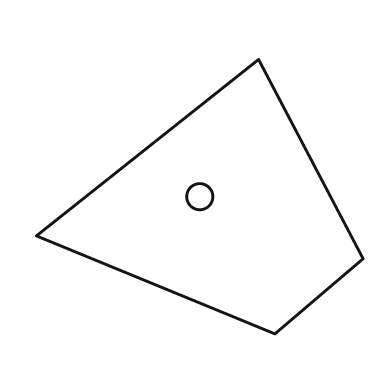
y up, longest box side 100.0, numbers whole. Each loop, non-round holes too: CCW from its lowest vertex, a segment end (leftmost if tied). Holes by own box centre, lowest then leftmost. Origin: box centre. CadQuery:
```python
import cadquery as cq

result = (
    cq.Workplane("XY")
    .moveTo(23.0, -42.0)
    .lineTo(50.0, -19.0)
    .lineTo(18.0, 42.0)
    .lineTo(-50.0, -12.0)
    .close()
    .moveTo(0.0, 0.0)
    .circle(4.0)
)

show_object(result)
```